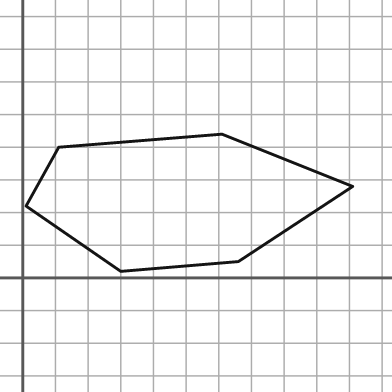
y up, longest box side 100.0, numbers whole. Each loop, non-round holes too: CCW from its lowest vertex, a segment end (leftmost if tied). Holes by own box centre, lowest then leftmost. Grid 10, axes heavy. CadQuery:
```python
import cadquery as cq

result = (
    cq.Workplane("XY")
    .moveTo(30.0, 2.0)
    .lineTo(66.0, 5.0)
    .lineTo(101.0, 28.0)
    .lineTo(61.0, 44.0)
    .lineTo(11.0, 40.0)
    .lineTo(1.0, 22.0)
    .close()
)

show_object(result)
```